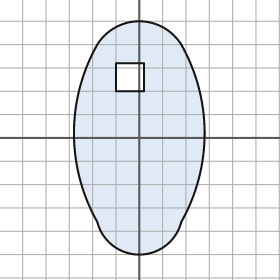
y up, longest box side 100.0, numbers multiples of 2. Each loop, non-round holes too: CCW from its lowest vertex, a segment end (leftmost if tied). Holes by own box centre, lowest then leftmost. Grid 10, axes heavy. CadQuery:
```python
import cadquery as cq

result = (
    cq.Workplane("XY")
    .moveTo(-18.0, -36.0)
    .threePointArc((0.0, -50.0), (18.0, -36.0))
    .threePointArc((28.0, 2.0), (18.0, 40.0))
    .threePointArc((0.0, 50.0), (-18.0, 40.0))
    .threePointArc((-28.0, 2.0), (-18.0, -36.0))
    .close()
    .moveTo(-10.0, 20.0)
    .lineTo(2.0, 20.0)
    .lineTo(2.0, 32.0)
    .lineTo(-10.0, 32.0)
    .close()
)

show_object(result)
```